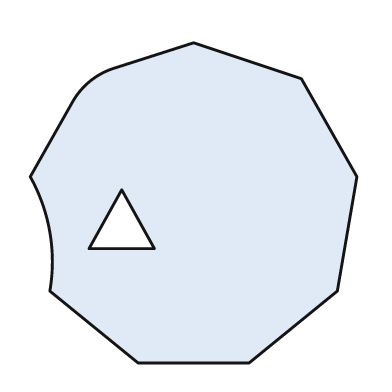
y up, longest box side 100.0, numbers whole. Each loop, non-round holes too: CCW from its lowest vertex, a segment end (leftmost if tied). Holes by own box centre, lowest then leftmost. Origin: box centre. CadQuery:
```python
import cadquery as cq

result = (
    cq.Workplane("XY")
    .moveTo(-17.0, -49.0)
    .lineTo(17.0, -49.0)
    .lineTo(44.0, -27.0)
    .lineTo(50.0, 8.0)
    .lineTo(33.0, 38.0)
    .lineTo(0.0, 49.0)
    .lineTo(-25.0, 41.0)
    .threePointArc((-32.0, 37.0), (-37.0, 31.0))
    .lineTo(-50.0, 8.0)
    .threePointArc((-44.0, -9.0), (-44.0, -27.0))
    .close()
    .moveTo(-32.0, -14.0)
    .lineTo(-12.0, -14.0)
    .lineTo(-22.0, 4.0)
    .close()
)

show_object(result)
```